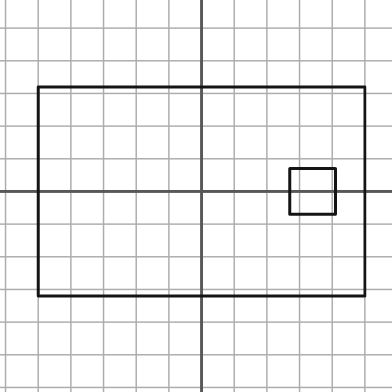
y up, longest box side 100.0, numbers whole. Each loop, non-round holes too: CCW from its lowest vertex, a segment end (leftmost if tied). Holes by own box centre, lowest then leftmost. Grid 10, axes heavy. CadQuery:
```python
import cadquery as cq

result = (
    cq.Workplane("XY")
    .moveTo(-50.0, -32.0)
    .lineTo(50.0, -32.0)
    .lineTo(50.0, 32.0)
    .lineTo(-50.0, 32.0)
    .close()
    .moveTo(27.0, -7.0)
    .lineTo(41.0, -7.0)
    .lineTo(41.0, 7.0)
    .lineTo(27.0, 7.0)
    .close()
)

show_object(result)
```